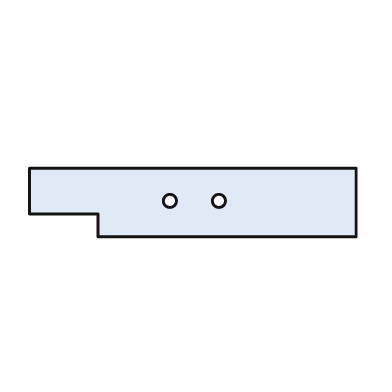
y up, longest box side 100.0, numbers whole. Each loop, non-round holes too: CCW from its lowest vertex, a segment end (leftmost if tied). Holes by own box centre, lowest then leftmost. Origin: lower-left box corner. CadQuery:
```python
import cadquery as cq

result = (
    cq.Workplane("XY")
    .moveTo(21.0, 0.0)
    .lineTo(100.0, 0.0)
    .lineTo(100.0, 21.0)
    .lineTo(0.0, 21.0)
    .lineTo(0.0, 7.0)
    .lineTo(21.0, 7.0)
    .close()
    .moveTo(43.0, 11.0)
    .circle(2.0)
    .moveTo(58.0, 11.0)
    .circle(2.0)
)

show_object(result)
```